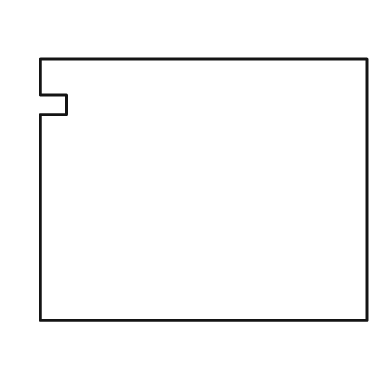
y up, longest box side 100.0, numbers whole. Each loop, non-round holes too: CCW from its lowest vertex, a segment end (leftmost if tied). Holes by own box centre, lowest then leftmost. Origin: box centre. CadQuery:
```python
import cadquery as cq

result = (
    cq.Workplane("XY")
    .moveTo(-50.0, -40.0)
    .lineTo(50.0, -40.0)
    .lineTo(50.0, 40.0)
    .lineTo(-50.0, 40.0)
    .lineTo(-50.0, 29.0)
    .lineTo(-42.0, 29.0)
    .lineTo(-42.0, 23.0)
    .lineTo(-50.0, 23.0)
    .close()
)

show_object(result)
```